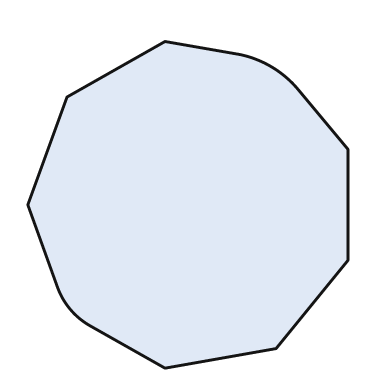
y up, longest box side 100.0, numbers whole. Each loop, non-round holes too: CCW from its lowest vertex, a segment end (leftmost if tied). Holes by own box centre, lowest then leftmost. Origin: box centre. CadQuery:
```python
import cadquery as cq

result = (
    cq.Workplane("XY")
    .moveTo(-7.0, -50.0)
    .lineTo(27.0, -44.0)
    .lineTo(49.0, -17.0)
    .lineTo(49.0, 17.0)
    .lineTo(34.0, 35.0)
    .threePointArc((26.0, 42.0), (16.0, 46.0))
    .lineTo(-7.0, 50.0)
    .lineTo(-37.0, 33.0)
    .lineTo(-49.0, 0.0)
    .lineTo(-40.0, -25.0)
    .threePointArc((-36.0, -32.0), (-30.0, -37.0))
    .close()
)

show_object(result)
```